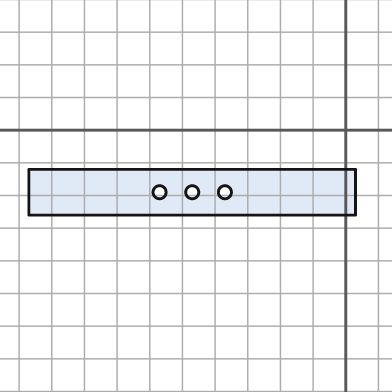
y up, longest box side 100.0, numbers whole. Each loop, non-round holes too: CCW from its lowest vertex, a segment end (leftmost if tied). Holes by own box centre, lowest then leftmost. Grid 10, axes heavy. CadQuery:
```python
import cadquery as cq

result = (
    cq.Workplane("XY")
    .moveTo(-97.0, -26.0)
    .lineTo(3.0, -26.0)
    .lineTo(3.0, -12.0)
    .lineTo(-97.0, -12.0)
    .close()
    .moveTo(-57.0, -19.0)
    .circle(2.0)
    .moveTo(-47.0, -19.0)
    .circle(2.0)
    .moveTo(-37.0, -19.0)
    .circle(2.0)
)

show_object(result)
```